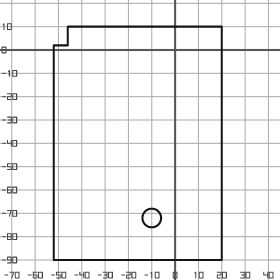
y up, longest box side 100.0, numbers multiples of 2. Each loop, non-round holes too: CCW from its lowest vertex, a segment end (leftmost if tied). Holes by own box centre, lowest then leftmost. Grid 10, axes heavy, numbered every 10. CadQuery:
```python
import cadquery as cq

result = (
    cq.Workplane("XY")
    .moveTo(-52.0, -90.0)
    .lineTo(20.0, -90.0)
    .lineTo(20.0, 10.0)
    .lineTo(-46.0, 10.0)
    .lineTo(-46.0, 2.0)
    .lineTo(-52.0, 2.0)
    .close()
    .moveTo(-10.0, -72.0)
    .circle(4.0)
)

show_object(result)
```